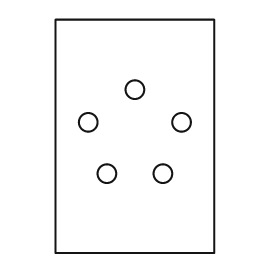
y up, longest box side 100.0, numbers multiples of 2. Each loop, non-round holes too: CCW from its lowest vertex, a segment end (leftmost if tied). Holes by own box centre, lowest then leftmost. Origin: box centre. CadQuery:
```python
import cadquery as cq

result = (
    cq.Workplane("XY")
    .moveTo(-34.0, -50.0)
    .lineTo(34.0, -50.0)
    .lineTo(34.0, 50.0)
    .lineTo(-34.0, 50.0)
    .close()
    .moveTo(-12.0, -16.0)
    .circle(4.0)
    .moveTo(12.0, -16.0)
    .circle(4.0)
    .moveTo(-20.0, 6.0)
    .circle(4.0)
    .moveTo(20.0, 6.0)
    .circle(4.0)
    .moveTo(0.0, 20.0)
    .circle(4.0)
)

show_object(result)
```